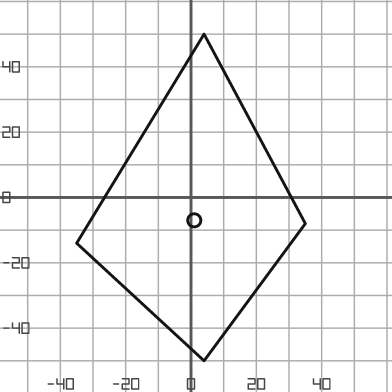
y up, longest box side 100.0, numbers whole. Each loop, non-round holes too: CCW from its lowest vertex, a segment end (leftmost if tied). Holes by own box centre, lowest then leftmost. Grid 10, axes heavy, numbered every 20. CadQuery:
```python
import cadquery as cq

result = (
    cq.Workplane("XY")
    .moveTo(4.0, -50.0)
    .lineTo(35.0, -8.0)
    .lineTo(4.0, 50.0)
    .lineTo(-35.0, -14.0)
    .close()
    .moveTo(1.0, -7.0)
    .circle(2.0)
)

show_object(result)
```